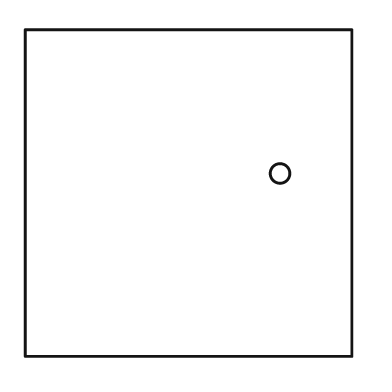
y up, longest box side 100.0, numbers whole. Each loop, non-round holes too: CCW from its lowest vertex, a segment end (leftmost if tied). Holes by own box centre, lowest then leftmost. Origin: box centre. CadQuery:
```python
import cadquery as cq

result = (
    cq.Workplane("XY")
    .moveTo(-50.0, -50.0)
    .lineTo(50.0, -50.0)
    .lineTo(50.0, 50.0)
    .lineTo(-50.0, 50.0)
    .close()
    .moveTo(28.0, 6.0)
    .circle(3.0)
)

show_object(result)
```